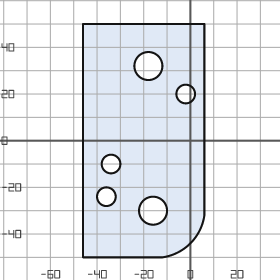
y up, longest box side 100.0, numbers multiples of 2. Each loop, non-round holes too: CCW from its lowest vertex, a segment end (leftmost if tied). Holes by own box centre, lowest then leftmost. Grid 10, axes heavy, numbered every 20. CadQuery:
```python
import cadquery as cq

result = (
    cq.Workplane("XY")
    .moveTo(-46.0, -50.0)
    .lineTo(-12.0, -50.0)
    .threePointArc((0.0, -44.0), (6.0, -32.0))
    .lineTo(6.0, 50.0)
    .lineTo(-46.0, 50.0)
    .close()
    .moveTo(-16.0, -30.0)
    .circle(6.0)
    .moveTo(-36.0, -24.0)
    .circle(4.0)
    .moveTo(-34.0, -10.0)
    .circle(4.0)
    .moveTo(-2.0, 20.0)
    .circle(4.0)
    .moveTo(-18.0, 32.0)
    .circle(6.0)
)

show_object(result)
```